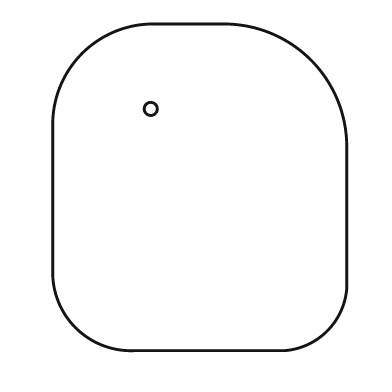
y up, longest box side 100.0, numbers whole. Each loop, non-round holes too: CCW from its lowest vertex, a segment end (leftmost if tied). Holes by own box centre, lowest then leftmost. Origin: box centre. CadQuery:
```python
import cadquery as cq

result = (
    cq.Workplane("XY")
    .moveTo(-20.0, -50.0)
    .lineTo(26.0, -50.0)
    .threePointArc((39.0, -44.0), (45.0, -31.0))
    .lineTo(45.0, 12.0)
    .threePointArc((34.0, 39.0), (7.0, 50.0))
    .lineTo(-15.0, 50.0)
    .threePointArc((-36.0, 41.0), (-45.0, 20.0))
    .lineTo(-45.0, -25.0)
    .threePointArc((-38.0, -43.0), (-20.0, -50.0))
    .close()
    .moveTo(-15.0, 24.0)
    .circle(2.0)
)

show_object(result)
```